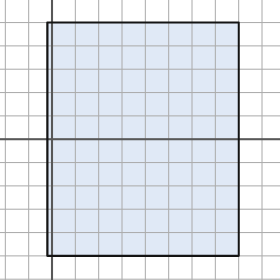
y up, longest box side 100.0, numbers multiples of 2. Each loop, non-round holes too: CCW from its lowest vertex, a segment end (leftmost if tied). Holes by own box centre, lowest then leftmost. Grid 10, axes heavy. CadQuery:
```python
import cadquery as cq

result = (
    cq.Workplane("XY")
    .moveTo(-2.0, -50.0)
    .lineTo(80.0, -50.0)
    .lineTo(80.0, 50.0)
    .lineTo(-2.0, 50.0)
    .close()
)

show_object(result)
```